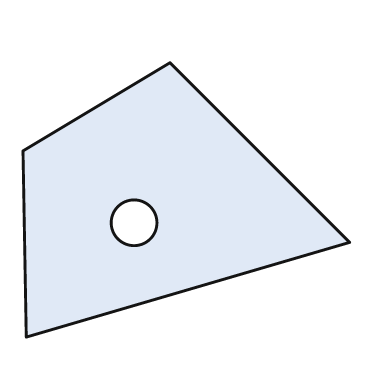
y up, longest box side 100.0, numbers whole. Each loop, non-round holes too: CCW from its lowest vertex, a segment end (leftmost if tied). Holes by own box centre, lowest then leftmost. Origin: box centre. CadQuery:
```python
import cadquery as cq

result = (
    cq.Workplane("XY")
    .moveTo(-49.0, -42.0)
    .lineTo(50.0, -13.0)
    .lineTo(-5.0, 42.0)
    .lineTo(-50.0, 15.0)
    .close()
    .moveTo(-16.0, -7.0)
    .circle(7.0)
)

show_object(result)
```